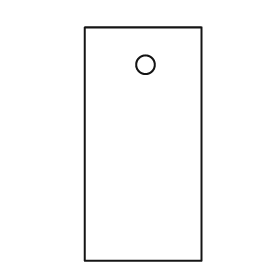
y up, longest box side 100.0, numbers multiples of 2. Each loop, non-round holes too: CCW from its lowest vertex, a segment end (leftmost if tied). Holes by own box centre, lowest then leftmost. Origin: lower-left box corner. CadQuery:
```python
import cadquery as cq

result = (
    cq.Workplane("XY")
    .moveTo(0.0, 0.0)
    .lineTo(50.0, 0.0)
    .lineTo(50.0, 100.0)
    .lineTo(0.0, 100.0)
    .close()
    .moveTo(26.0, 84.0)
    .circle(4.0)
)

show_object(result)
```